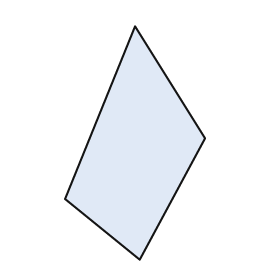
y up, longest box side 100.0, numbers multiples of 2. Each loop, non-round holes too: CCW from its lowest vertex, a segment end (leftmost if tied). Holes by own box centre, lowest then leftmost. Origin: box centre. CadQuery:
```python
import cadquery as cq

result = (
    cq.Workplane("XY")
    .moveTo(2.0, -50.0)
    .lineTo(30.0, 2.0)
    .lineTo(0.0, 50.0)
    .lineTo(-30.0, -24.0)
    .close()
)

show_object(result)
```